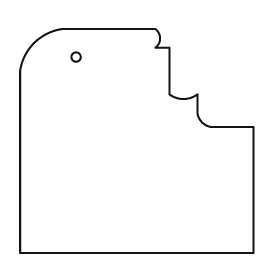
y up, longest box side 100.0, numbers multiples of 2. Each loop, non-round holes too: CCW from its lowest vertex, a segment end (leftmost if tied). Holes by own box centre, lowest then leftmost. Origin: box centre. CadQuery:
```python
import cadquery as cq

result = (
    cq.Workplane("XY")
    .moveTo(-50.0, -48.0)
    .lineTo(50.0, -48.0)
    .lineTo(50.0, 6.0)
    .lineTo(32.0, 6.0)
    .threePointArc((28.0, 8.0), (26.0, 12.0))
    .lineTo(26.0, 20.0)
    .threePointArc((20.0, 18.0), (14.0, 20.0))
    .lineTo(14.0, 40.0)
    .lineTo(8.0, 40.0)
    .threePointArc((10.0, 44.0), (8.0, 48.0))
    .lineTo(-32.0, 48.0)
    .threePointArc((-44.0, 42.0), (-50.0, 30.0))
    .close()
    .moveTo(-26.0, 36.0)
    .circle(2.0)
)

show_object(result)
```